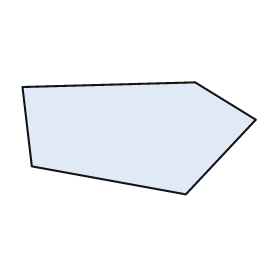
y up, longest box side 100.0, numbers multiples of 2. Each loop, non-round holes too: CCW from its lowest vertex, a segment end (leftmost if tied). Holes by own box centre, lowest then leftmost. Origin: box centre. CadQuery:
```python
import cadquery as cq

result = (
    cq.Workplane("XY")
    .moveTo(20.0, -24.0)
    .lineTo(50.0, 8.0)
    .lineTo(24.0, 24.0)
    .lineTo(-50.0, 22.0)
    .lineTo(-46.0, -12.0)
    .close()
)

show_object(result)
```